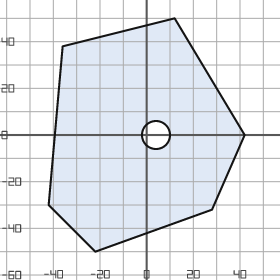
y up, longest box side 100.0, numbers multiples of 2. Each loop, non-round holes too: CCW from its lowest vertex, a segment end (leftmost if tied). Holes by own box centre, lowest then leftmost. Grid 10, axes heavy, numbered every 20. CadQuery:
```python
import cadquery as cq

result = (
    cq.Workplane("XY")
    .moveTo(-22.0, -50.0)
    .lineTo(28.0, -32.0)
    .lineTo(42.0, 0.0)
    .lineTo(12.0, 50.0)
    .lineTo(-36.0, 38.0)
    .lineTo(-42.0, -30.0)
    .close()
    .moveTo(4.0, 0.0)
    .circle(6.0)
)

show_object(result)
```